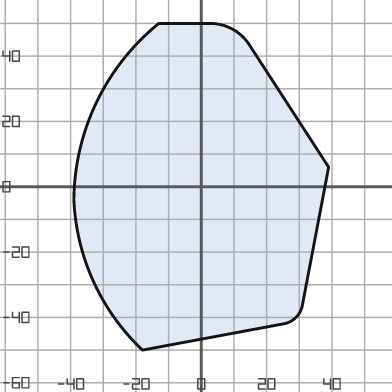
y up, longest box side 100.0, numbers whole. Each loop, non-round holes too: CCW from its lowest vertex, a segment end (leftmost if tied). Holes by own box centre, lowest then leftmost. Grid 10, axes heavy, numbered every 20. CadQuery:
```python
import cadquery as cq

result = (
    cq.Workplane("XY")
    .moveTo(-18.0, -50.0)
    .lineTo(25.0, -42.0)
    .threePointArc((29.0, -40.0), (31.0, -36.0))
    .lineTo(39.0, 6.0)
    .lineTo(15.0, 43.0)
    .threePointArc((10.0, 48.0), (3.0, 50.0))
    .lineTo(-13.0, 50.0)
    .threePointArc((-32.0, 26.0), (-39.0, -4.0))
    .threePointArc((-33.0, -29.0), (-18.0, -50.0))
    .close()
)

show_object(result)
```